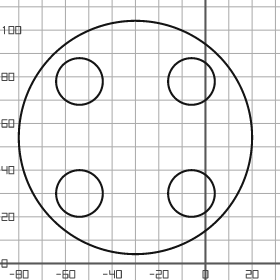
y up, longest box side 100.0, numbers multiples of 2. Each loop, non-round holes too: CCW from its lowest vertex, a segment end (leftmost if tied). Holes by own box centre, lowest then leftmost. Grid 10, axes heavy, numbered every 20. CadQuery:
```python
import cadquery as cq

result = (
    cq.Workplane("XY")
    .moveTo(-30.0, 54.0)
    .circle(50.0)
    .moveTo(-54.0, 30.0)
    .circle(10.0)
    .moveTo(-6.0, 30.0)
    .circle(10.0)
    .moveTo(-54.0, 78.0)
    .circle(10.0)
    .moveTo(-6.0, 78.0)
    .circle(10.0)
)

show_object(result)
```